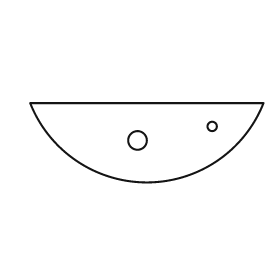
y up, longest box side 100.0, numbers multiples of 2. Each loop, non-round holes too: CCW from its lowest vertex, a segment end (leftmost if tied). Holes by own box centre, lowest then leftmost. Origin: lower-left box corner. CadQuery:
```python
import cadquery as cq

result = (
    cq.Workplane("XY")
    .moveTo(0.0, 34.0)
    .threePointArc((50.0, 0.0), (100.0, 34.0))
    .close()
    .moveTo(46.0, 18.0)
    .circle(4.0)
    .moveTo(78.0, 24.0)
    .circle(2.0)
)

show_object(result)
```